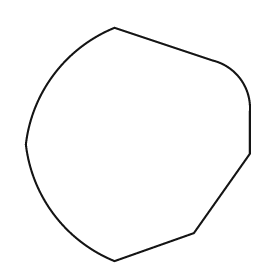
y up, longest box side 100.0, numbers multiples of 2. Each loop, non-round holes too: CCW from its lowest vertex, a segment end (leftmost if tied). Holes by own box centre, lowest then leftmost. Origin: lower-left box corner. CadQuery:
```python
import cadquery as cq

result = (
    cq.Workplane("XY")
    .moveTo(38.0, 0.0)
    .lineTo(72.0, 12.0)
    .lineTo(96.0, 46.0)
    .lineTo(96.0, 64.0)
    .threePointArc((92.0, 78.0), (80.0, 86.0))
    .lineTo(38.0, 100.0)
    .threePointArc((12.0, 80.0), (0.0, 50.0))
    .threePointArc((12.0, 20.0), (38.0, 0.0))
    .close()
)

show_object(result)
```